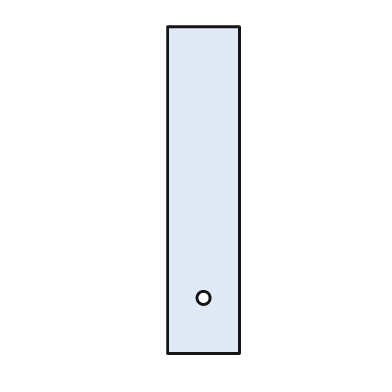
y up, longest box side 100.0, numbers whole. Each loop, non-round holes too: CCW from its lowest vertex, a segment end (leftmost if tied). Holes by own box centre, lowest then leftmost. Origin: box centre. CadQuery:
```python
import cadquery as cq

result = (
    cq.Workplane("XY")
    .moveTo(-11.0, -50.0)
    .lineTo(11.0, -50.0)
    .lineTo(11.0, 50.0)
    .lineTo(-11.0, 50.0)
    .close()
    .moveTo(0.0, -33.0)
    .circle(2.0)
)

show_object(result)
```